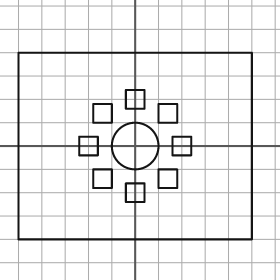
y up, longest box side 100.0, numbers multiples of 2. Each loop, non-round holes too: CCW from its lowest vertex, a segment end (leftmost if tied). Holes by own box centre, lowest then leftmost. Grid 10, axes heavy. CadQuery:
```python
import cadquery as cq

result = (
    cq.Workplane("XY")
    .moveTo(-50.0, -40.0)
    .lineTo(50.0, -40.0)
    .lineTo(50.0, 40.0)
    .lineTo(-50.0, 40.0)
    .close()
    .moveTo(-4.0, -24.0)
    .lineTo(4.0, -24.0)
    .lineTo(4.0, -16.0)
    .lineTo(-4.0, -16.0)
    .close()
    .moveTo(-18.0, -18.0)
    .lineTo(-10.0, -18.0)
    .lineTo(-10.0, -10.0)
    .lineTo(-18.0, -10.0)
    .close()
    .moveTo(10.0, -18.0)
    .lineTo(18.0, -18.0)
    .lineTo(18.0, -10.0)
    .lineTo(10.0, -10.0)
    .close()
    .moveTo(-24.0, -4.0)
    .lineTo(-16.0, -4.0)
    .lineTo(-16.0, 4.0)
    .lineTo(-24.0, 4.0)
    .close()
    .moveTo(0.0, 0.0)
    .circle(10.0)
    .moveTo(16.0, -4.0)
    .lineTo(24.0, -4.0)
    .lineTo(24.0, 4.0)
    .lineTo(16.0, 4.0)
    .close()
    .moveTo(-18.0, 10.0)
    .lineTo(-10.0, 10.0)
    .lineTo(-10.0, 18.0)
    .lineTo(-18.0, 18.0)
    .close()
    .moveTo(10.0, 10.0)
    .lineTo(18.0, 10.0)
    .lineTo(18.0, 18.0)
    .lineTo(10.0, 18.0)
    .close()
    .moveTo(-4.0, 16.0)
    .lineTo(4.0, 16.0)
    .lineTo(4.0, 24.0)
    .lineTo(-4.0, 24.0)
    .close()
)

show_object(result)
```